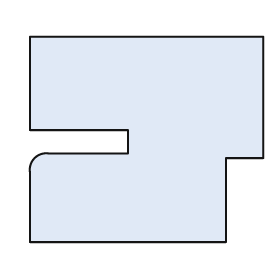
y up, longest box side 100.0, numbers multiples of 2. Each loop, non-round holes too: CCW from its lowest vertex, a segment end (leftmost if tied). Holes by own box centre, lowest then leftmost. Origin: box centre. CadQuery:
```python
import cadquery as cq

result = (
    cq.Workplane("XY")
    .moveTo(-50.0, -44.0)
    .lineTo(34.0, -44.0)
    .lineTo(34.0, -8.0)
    .lineTo(50.0, -8.0)
    .lineTo(50.0, 44.0)
    .lineTo(-50.0, 44.0)
    .lineTo(-50.0, 4.0)
    .lineTo(-8.0, 4.0)
    .lineTo(-8.0, -6.0)
    .lineTo(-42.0, -6.0)
    .threePointArc((-48.0, -8.0), (-50.0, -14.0))
    .close()
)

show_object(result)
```